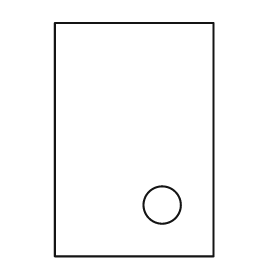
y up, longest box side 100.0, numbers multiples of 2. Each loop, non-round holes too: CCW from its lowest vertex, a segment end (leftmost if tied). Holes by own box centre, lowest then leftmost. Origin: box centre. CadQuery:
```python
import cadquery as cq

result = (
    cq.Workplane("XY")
    .moveTo(-34.0, -50.0)
    .lineTo(34.0, -50.0)
    .lineTo(34.0, 50.0)
    .lineTo(-34.0, 50.0)
    .close()
    .moveTo(12.0, -28.0)
    .circle(8.0)
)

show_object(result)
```